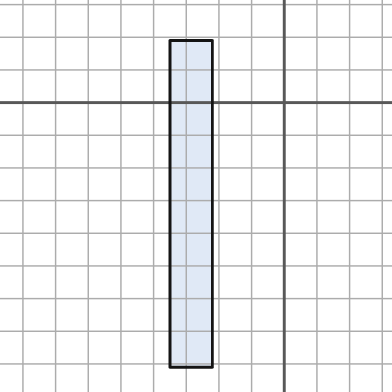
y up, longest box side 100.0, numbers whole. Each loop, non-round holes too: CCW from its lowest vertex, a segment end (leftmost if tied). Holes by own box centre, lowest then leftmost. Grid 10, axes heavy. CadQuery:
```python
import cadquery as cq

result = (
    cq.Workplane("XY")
    .moveTo(-35.0, -81.0)
    .lineTo(-22.0, -81.0)
    .lineTo(-22.0, 19.0)
    .lineTo(-35.0, 19.0)
    .close()
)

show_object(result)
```